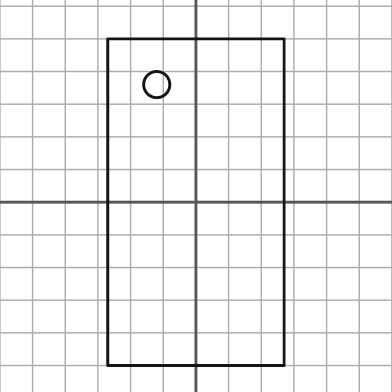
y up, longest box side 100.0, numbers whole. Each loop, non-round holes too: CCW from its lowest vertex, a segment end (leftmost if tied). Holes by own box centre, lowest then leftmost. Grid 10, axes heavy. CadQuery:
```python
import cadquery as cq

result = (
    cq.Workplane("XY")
    .moveTo(-27.0, -50.0)
    .lineTo(27.0, -50.0)
    .lineTo(27.0, 50.0)
    .lineTo(-27.0, 50.0)
    .close()
    .moveTo(-12.0, 36.0)
    .circle(4.0)
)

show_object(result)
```